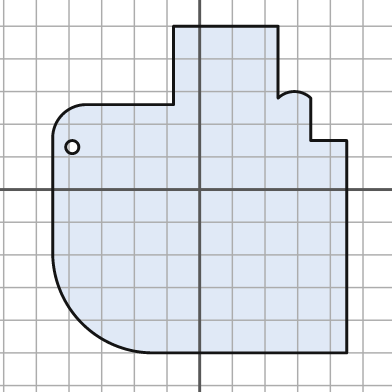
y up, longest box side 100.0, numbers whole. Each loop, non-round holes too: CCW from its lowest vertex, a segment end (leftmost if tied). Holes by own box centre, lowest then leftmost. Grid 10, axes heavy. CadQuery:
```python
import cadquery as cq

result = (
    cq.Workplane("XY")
    .moveTo(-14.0, -50.0)
    .lineTo(45.0, -50.0)
    .lineTo(45.0, 15.0)
    .lineTo(34.0, 15.0)
    .lineTo(34.0, 28.0)
    .threePointArc((29.0, 30.0), (24.0, 28.0))
    .lineTo(24.0, 50.0)
    .lineTo(-8.0, 50.0)
    .lineTo(-8.0, 26.0)
    .lineTo(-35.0, 26.0)
    .threePointArc((-42.0, 23.0), (-45.0, 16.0))
    .lineTo(-45.0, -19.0)
    .threePointArc((-36.0, -41.0), (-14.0, -50.0))
    .close()
    .moveTo(-39.0, 13.0)
    .circle(2.0)
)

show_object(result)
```